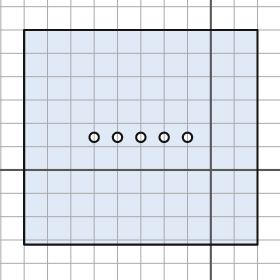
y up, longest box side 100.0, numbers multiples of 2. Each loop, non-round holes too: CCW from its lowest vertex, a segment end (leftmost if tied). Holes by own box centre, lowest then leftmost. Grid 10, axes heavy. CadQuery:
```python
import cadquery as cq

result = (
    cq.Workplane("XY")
    .moveTo(-80.0, -32.0)
    .lineTo(20.0, -32.0)
    .lineTo(20.0, 60.0)
    .lineTo(-80.0, 60.0)
    .close()
    .moveTo(-50.0, 14.0)
    .circle(2.0)
    .moveTo(-40.0, 14.0)
    .circle(2.0)
    .moveTo(-30.0, 14.0)
    .circle(2.0)
    .moveTo(-20.0, 14.0)
    .circle(2.0)
    .moveTo(-10.0, 14.0)
    .circle(2.0)
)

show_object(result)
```